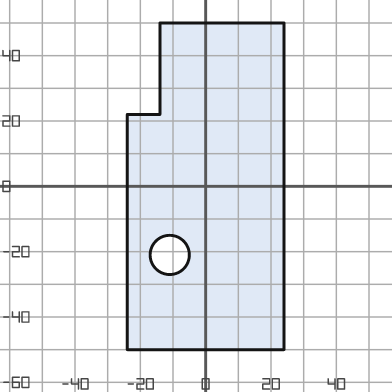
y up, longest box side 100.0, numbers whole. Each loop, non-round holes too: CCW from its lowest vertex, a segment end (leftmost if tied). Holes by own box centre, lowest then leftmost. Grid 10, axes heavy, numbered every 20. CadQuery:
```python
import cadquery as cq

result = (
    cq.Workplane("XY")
    .moveTo(-24.0, -50.0)
    .lineTo(24.0, -50.0)
    .lineTo(24.0, 50.0)
    .lineTo(-14.0, 50.0)
    .lineTo(-14.0, 22.0)
    .lineTo(-24.0, 22.0)
    .close()
    .moveTo(-11.0, -21.0)
    .circle(6.0)
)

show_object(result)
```